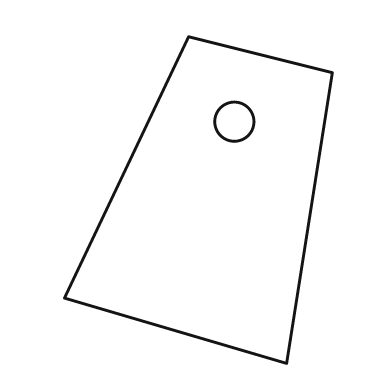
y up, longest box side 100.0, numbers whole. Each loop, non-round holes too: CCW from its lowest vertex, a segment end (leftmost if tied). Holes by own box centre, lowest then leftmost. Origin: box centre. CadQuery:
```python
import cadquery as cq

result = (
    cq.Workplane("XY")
    .moveTo(27.0, -50.0)
    .lineTo(41.0, 39.0)
    .lineTo(-3.0, 50.0)
    .lineTo(-41.0, -30.0)
    .close()
    .moveTo(11.0, 24.0)
    .circle(6.0)
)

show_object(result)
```